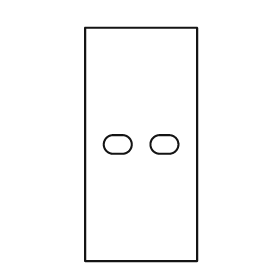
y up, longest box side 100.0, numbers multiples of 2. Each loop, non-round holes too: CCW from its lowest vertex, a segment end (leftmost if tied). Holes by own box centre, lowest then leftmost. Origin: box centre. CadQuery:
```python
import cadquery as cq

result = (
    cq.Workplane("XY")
    .moveTo(-24.0, -50.0)
    .lineTo(24.0, -50.0)
    .lineTo(24.0, 50.0)
    .lineTo(-24.0, 50.0)
    .close()
    .moveTo(-12.0, -4.0)
    .lineTo(-8.0, -4.0)
    .threePointArc((-4.0, 0.0), (-8.0, 4.0))
    .lineTo(-12.0, 4.0)
    .threePointArc((-16.0, 0.0), (-12.0, -4.0))
    .close()
    .moveTo(8.0, -4.0)
    .lineTo(12.0, -4.0)
    .threePointArc((16.0, 0.0), (12.0, 4.0))
    .lineTo(8.0, 4.0)
    .threePointArc((4.0, 0.0), (8.0, -4.0))
    .close()
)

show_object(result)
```